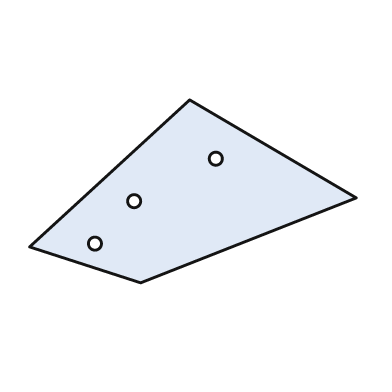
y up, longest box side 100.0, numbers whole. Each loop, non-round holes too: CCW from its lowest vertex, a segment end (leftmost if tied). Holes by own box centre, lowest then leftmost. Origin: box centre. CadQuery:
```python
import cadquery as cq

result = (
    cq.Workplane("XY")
    .moveTo(-16.0, -28.0)
    .lineTo(50.0, -2.0)
    .lineTo(-1.0, 28.0)
    .lineTo(-50.0, -17.0)
    .close()
    .moveTo(-30.0, -16.0)
    .circle(2.0)
    .moveTo(-18.0, -3.0)
    .circle(2.0)
    .moveTo(7.0, 10.0)
    .circle(2.0)
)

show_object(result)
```